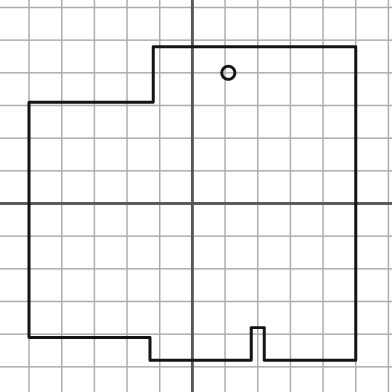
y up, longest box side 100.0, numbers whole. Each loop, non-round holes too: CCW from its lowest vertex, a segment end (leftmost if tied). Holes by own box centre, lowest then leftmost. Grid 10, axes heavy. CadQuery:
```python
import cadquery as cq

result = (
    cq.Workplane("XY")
    .moveTo(-13.0, -48.0)
    .lineTo(18.0, -48.0)
    .lineTo(18.0, -38.0)
    .lineTo(22.0, -38.0)
    .lineTo(22.0, -48.0)
    .lineTo(50.0, -48.0)
    .lineTo(50.0, 48.0)
    .lineTo(-12.0, 48.0)
    .lineTo(-12.0, 31.0)
    .lineTo(-50.0, 31.0)
    .lineTo(-50.0, -41.0)
    .lineTo(-13.0, -41.0)
    .close()
    .moveTo(11.0, 40.0)
    .circle(2.0)
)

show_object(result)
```